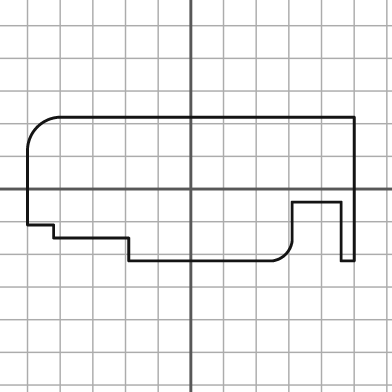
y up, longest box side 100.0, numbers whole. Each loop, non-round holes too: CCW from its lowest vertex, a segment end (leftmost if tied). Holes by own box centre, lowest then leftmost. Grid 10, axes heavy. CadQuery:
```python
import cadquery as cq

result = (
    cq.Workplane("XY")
    .moveTo(-19.0, -22.0)
    .lineTo(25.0, -22.0)
    .threePointArc((29.0, -20.0), (31.0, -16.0))
    .lineTo(31.0, -4.0)
    .lineTo(46.0, -4.0)
    .lineTo(46.0, -22.0)
    .lineTo(50.0, -22.0)
    .lineTo(50.0, 22.0)
    .lineTo(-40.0, 22.0)
    .threePointArc((-47.0, 19.0), (-50.0, 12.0))
    .lineTo(-50.0, -11.0)
    .lineTo(-42.0, -11.0)
    .lineTo(-42.0, -15.0)
    .lineTo(-19.0, -15.0)
    .close()
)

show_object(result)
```